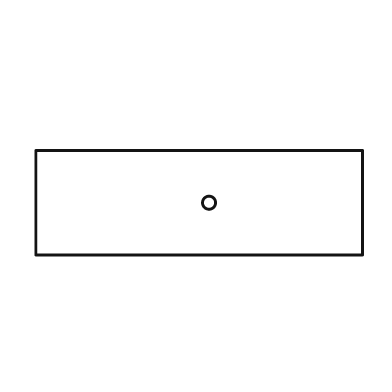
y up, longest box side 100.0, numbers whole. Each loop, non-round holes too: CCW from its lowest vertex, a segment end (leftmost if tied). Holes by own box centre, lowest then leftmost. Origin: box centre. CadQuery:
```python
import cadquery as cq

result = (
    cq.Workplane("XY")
    .moveTo(-50.0, -16.0)
    .lineTo(50.0, -16.0)
    .lineTo(50.0, 16.0)
    .lineTo(-50.0, 16.0)
    .close()
    .moveTo(3.0, 0.0)
    .circle(2.0)
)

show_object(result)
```